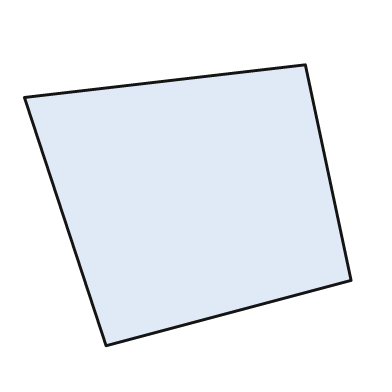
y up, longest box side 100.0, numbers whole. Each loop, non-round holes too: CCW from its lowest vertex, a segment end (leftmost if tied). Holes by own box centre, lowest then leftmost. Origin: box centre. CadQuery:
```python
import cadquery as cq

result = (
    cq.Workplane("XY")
    .moveTo(-25.0, -43.0)
    .lineTo(50.0, -23.0)
    .lineTo(36.0, 43.0)
    .lineTo(-50.0, 33.0)
    .close()
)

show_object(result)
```